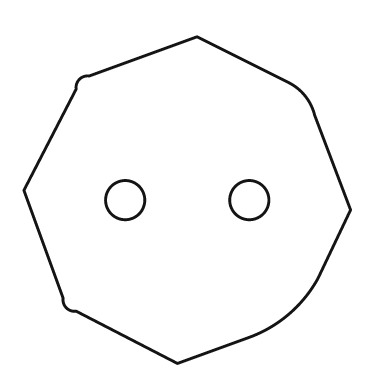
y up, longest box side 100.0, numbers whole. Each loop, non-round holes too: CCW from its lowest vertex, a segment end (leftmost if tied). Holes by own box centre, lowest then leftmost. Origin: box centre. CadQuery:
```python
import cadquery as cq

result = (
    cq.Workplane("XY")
    .moveTo(-3.0, -50.0)
    .lineTo(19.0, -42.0)
    .threePointArc((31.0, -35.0), (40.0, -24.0))
    .lineTo(50.0, -3.0)
    .lineTo(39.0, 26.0)
    .threePointArc((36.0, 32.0), (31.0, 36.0))
    .lineTo(3.0, 50.0)
    .lineTo(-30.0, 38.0)
    .threePointArc((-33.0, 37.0), (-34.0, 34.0))
    .lineTo(-50.0, 3.0)
    .lineTo(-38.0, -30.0)
    .threePointArc((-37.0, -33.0), (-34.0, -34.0))
    .close()
    .moveTo(-19.0, 0.0)
    .circle(6.0)
    .moveTo(19.0, 0.0)
    .circle(6.0)
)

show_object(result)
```